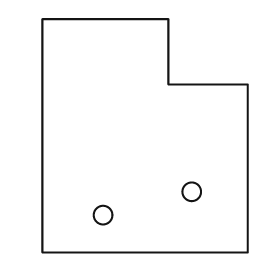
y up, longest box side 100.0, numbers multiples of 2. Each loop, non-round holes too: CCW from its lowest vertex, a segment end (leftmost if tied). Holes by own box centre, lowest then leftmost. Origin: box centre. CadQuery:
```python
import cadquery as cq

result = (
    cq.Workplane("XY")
    .moveTo(-44.0, -50.0)
    .lineTo(44.0, -50.0)
    .lineTo(44.0, 22.0)
    .lineTo(10.0, 22.0)
    .lineTo(10.0, 50.0)
    .lineTo(-44.0, 50.0)
    .close()
    .moveTo(-18.0, -34.0)
    .circle(4.0)
    .moveTo(20.0, -24.0)
    .circle(4.0)
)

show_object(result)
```